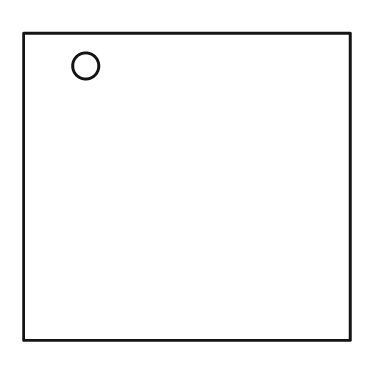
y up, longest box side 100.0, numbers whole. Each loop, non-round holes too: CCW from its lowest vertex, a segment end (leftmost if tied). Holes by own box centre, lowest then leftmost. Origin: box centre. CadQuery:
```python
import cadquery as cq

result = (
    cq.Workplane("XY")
    .moveTo(-50.0, -47.0)
    .lineTo(50.0, -47.0)
    .lineTo(50.0, 47.0)
    .lineTo(-50.0, 47.0)
    .close()
    .moveTo(-31.0, 37.0)
    .circle(4.0)
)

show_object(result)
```